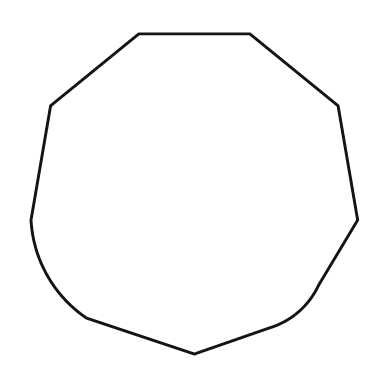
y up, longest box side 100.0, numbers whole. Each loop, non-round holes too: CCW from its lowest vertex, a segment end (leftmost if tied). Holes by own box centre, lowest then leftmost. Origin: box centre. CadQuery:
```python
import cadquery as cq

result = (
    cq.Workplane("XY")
    .moveTo(0.0, -49.0)
    .lineTo(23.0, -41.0)
    .threePointArc((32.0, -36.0), (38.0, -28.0))
    .lineTo(50.0, -8.0)
    .lineTo(44.0, 27.0)
    .lineTo(17.0, 49.0)
    .lineTo(-17.0, 49.0)
    .lineTo(-44.0, 27.0)
    .lineTo(-50.0, -8.0)
    .threePointArc((-45.0, -25.0), (-33.0, -38.0))
    .close()
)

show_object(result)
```